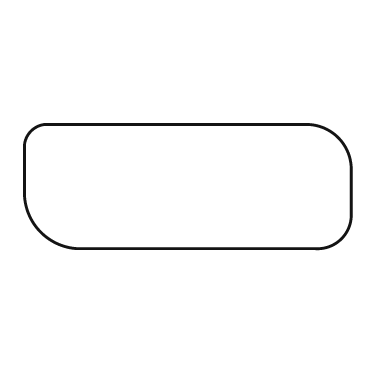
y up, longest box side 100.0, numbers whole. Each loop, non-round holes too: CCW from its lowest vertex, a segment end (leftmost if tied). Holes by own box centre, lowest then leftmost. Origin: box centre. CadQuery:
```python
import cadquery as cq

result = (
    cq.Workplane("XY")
    .moveTo(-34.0, -19.0)
    .lineTo(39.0, -19.0)
    .threePointArc((47.0, -16.0), (50.0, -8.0))
    .lineTo(50.0, 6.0)
    .threePointArc((46.0, 15.0), (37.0, 19.0))
    .lineTo(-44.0, 19.0)
    .threePointArc((-48.0, 17.0), (-50.0, 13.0))
    .lineTo(-50.0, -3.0)
    .threePointArc((-45.0, -14.0), (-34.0, -19.0))
    .close()
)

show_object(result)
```